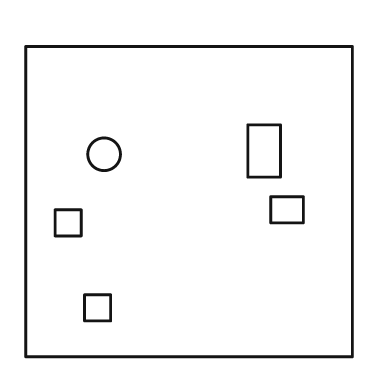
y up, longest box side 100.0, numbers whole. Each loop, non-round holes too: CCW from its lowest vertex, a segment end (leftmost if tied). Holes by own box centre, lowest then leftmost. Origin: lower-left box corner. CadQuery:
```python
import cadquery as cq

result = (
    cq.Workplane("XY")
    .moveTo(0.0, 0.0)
    .lineTo(100.0, 0.0)
    .lineTo(100.0, 95.0)
    .lineTo(0.0, 95.0)
    .close()
    .moveTo(18.0, 11.0)
    .lineTo(26.0, 11.0)
    .lineTo(26.0, 19.0)
    .lineTo(18.0, 19.0)
    .close()
    .moveTo(9.0, 37.0)
    .lineTo(17.0, 37.0)
    .lineTo(17.0, 45.0)
    .lineTo(9.0, 45.0)
    .close()
    .moveTo(75.0, 41.0)
    .lineTo(85.0, 41.0)
    .lineTo(85.0, 49.0)
    .lineTo(75.0, 49.0)
    .close()
    .moveTo(24.0, 62.0)
    .circle(5.0)
    .moveTo(68.0, 55.0)
    .lineTo(78.0, 55.0)
    .lineTo(78.0, 71.0)
    .lineTo(68.0, 71.0)
    .close()
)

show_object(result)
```